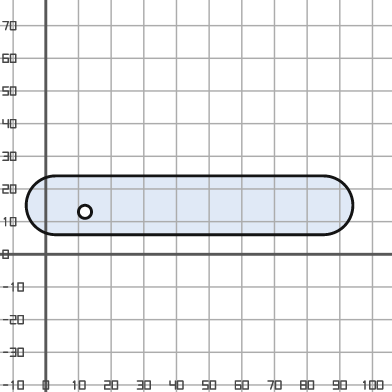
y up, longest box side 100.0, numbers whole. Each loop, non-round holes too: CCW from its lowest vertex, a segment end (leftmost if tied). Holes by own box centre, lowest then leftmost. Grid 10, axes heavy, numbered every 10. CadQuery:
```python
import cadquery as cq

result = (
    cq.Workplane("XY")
    .moveTo(3.0, 6.0)
    .lineTo(85.0, 6.0)
    .threePointArc((94.0, 15.0), (85.0, 24.0))
    .lineTo(3.0, 24.0)
    .threePointArc((-6.0, 15.0), (3.0, 6.0))
    .close()
    .moveTo(12.0, 13.0)
    .circle(2.0)
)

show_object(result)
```